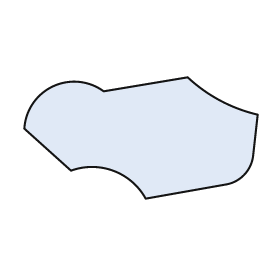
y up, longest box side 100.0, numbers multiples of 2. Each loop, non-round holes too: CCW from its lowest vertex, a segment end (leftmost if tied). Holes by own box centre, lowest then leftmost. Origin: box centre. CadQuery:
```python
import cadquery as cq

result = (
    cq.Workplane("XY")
    .moveTo(2.0, -26.0)
    .lineTo(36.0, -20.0)
    .threePointArc((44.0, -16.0), (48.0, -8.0))
    .lineTo(50.0, 10.0)
    .threePointArc((34.0, 16.0), (20.0, 26.0))
    .lineTo(-16.0, 20.0)
    .threePointArc((-38.0, 22.0), (-50.0, 4.0))
    .lineTo(-30.0, -14.0)
    .threePointArc((-12.0, -14.0), (2.0, -26.0))
    .close()
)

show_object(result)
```